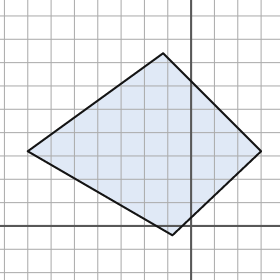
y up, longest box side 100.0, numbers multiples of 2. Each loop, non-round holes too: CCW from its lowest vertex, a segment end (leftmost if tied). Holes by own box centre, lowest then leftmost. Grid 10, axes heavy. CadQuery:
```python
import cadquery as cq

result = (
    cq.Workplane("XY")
    .moveTo(-8.0, -4.0)
    .lineTo(30.0, 32.0)
    .lineTo(-12.0, 74.0)
    .lineTo(-70.0, 32.0)
    .close()
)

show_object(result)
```